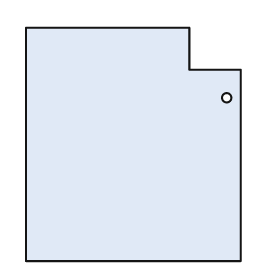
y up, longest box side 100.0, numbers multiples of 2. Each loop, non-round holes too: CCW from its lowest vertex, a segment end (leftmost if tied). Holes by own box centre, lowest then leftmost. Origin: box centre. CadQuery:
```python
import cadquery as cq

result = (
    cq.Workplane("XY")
    .moveTo(-46.0, -50.0)
    .lineTo(46.0, -50.0)
    .lineTo(46.0, 32.0)
    .lineTo(24.0, 32.0)
    .lineTo(24.0, 50.0)
    .lineTo(-46.0, 50.0)
    .close()
    .moveTo(40.0, 20.0)
    .circle(2.0)
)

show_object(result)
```